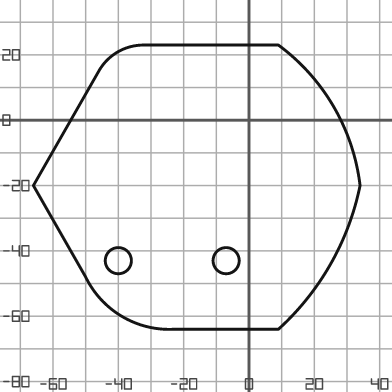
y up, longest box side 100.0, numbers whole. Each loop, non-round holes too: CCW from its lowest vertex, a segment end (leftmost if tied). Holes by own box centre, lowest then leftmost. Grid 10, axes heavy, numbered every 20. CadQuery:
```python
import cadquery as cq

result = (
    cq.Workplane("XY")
    .moveTo(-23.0, -64.0)
    .lineTo(9.0, -64.0)
    .threePointArc((25.0, -44.0), (34.0, -20.0))
    .threePointArc((26.0, 4.0), (9.0, 23.0))
    .lineTo(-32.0, 23.0)
    .threePointArc((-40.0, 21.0), (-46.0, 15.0))
    .lineTo(-66.0, -20.0)
    .lineTo(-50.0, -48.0)
    .threePointArc((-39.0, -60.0), (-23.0, -64.0))
    .close()
    .moveTo(-40.0, -43.0)
    .circle(4.0)
    .moveTo(-7.0, -43.0)
    .circle(4.0)
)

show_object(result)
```